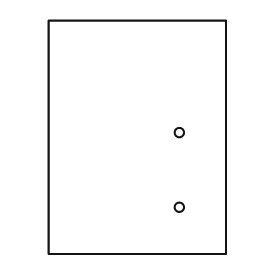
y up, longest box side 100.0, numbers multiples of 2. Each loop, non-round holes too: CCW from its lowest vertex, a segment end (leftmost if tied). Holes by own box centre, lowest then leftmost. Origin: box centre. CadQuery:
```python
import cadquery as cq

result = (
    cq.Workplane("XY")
    .moveTo(-38.0, -50.0)
    .lineTo(38.0, -50.0)
    .lineTo(38.0, 50.0)
    .lineTo(-38.0, 50.0)
    .close()
    .moveTo(18.0, -30.0)
    .circle(2.0)
    .moveTo(18.0, 2.0)
    .circle(2.0)
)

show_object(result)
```